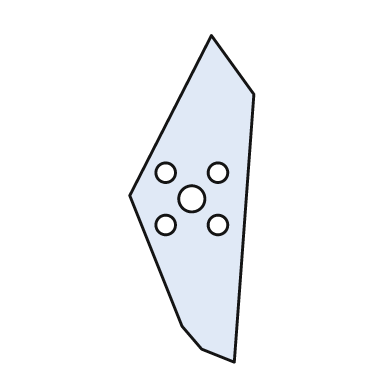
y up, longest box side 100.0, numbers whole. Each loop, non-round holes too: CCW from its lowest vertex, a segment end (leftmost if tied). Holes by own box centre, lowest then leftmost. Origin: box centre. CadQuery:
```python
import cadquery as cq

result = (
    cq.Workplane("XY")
    .moveTo(13.0, -50.0)
    .lineTo(19.0, 32.0)
    .lineTo(6.0, 50.0)
    .lineTo(-19.0, 1.0)
    .lineTo(-3.0, -39.0)
    .lineTo(3.0, -46.0)
    .close()
    .moveTo(-8.0, -8.0)
    .circle(3.0)
    .moveTo(8.0, -8.0)
    .circle(3.0)
    .moveTo(0.0, 0.0)
    .circle(4.0)
    .moveTo(-8.0, 8.0)
    .circle(3.0)
    .moveTo(8.0, 8.0)
    .circle(3.0)
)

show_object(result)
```